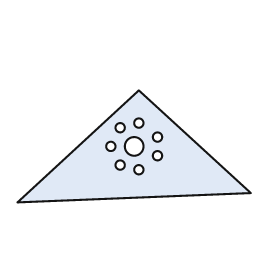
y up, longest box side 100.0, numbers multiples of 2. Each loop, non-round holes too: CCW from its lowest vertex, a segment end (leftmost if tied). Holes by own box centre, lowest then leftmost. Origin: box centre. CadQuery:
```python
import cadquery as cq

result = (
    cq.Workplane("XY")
    .moveTo(-50.0, -24.0)
    .lineTo(50.0, -20.0)
    .lineTo(2.0, 24.0)
    .close()
    .moveTo(2.0, -10.0)
    .circle(2.0)
    .moveTo(-6.0, -8.0)
    .circle(2.0)
    .moveTo(10.0, -4.0)
    .circle(2.0)
    .moveTo(-10.0, 0.0)
    .circle(2.0)
    .moveTo(0.0, 0.0)
    .circle(4.0)
    .moveTo(10.0, 4.0)
    .circle(2.0)
    .moveTo(-6.0, 8.0)
    .circle(2.0)
    .moveTo(2.0, 10.0)
    .circle(2.0)
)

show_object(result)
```